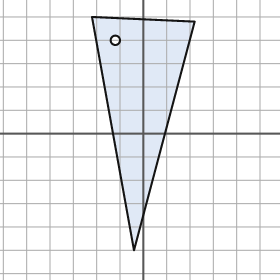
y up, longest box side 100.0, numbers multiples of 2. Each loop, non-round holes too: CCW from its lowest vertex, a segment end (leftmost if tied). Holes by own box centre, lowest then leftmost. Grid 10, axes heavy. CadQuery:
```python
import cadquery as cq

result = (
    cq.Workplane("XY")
    .moveTo(-4.0, -50.0)
    .lineTo(22.0, 48.0)
    .lineTo(-22.0, 50.0)
    .close()
    .moveTo(-12.0, 40.0)
    .circle(2.0)
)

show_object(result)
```